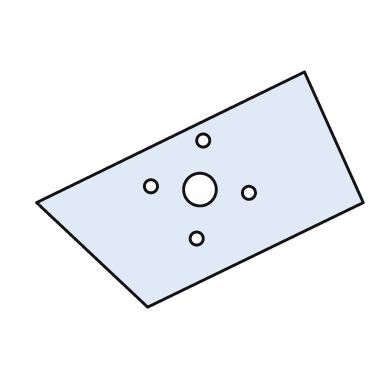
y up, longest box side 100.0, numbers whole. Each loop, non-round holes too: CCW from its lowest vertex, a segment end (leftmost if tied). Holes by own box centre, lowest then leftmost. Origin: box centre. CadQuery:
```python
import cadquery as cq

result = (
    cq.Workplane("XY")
    .moveTo(-16.0, -36.0)
    .lineTo(50.0, -4.0)
    .lineTo(32.0, 36.0)
    .lineTo(-50.0, -4.0)
    .close()
    .moveTo(-1.0, -15.0)
    .circle(2.0)
    .moveTo(15.0, -1.0)
    .circle(2.0)
    .moveTo(0.0, 0.0)
    .circle(5.0)
    .moveTo(-15.0, 1.0)
    .circle(2.0)
    .moveTo(1.0, 15.0)
    .circle(2.0)
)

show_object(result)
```